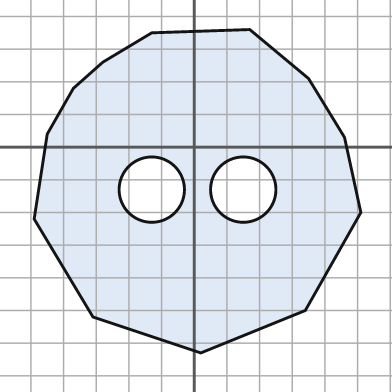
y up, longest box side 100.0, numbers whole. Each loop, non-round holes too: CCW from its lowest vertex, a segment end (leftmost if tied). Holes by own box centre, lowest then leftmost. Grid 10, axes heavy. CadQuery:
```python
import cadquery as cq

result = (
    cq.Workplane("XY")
    .moveTo(2.0, -63.0)
    .lineTo(34.0, -50.0)
    .lineTo(51.0, -20.0)
    .lineTo(46.0, 3.0)
    .lineTo(35.0, 21.0)
    .lineTo(17.0, 36.0)
    .lineTo(-13.0, 35.0)
    .lineTo(-28.0, 26.0)
    .lineTo(-37.0, 18.0)
    .lineTo(-45.0, 4.0)
    .lineTo(-49.0, -22.0)
    .lineTo(-31.0, -52.0)
    .close()
    .moveTo(-13.0, -13.0)
    .circle(10.0)
    .moveTo(15.0, -13.0)
    .circle(10.0)
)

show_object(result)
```